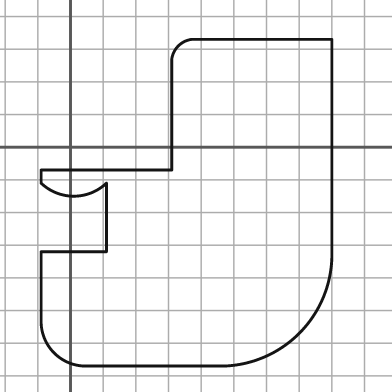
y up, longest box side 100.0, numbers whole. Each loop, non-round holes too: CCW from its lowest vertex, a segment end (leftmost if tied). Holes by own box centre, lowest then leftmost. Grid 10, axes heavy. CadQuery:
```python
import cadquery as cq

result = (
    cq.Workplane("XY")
    .moveTo(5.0, -67.0)
    .lineTo(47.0, -67.0)
    .threePointArc((70.0, -57.0), (80.0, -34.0))
    .lineTo(80.0, 33.0)
    .lineTo(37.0, 33.0)
    .threePointArc((33.0, 31.0), (31.0, 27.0))
    .lineTo(31.0, -7.0)
    .lineTo(-9.0, -7.0)
    .lineTo(-9.0, -11.0)
    .threePointArc((1.0, -15.0), (11.0, -11.0))
    .lineTo(11.0, -32.0)
    .lineTo(-9.0, -32.0)
    .lineTo(-9.0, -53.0)
    .threePointArc((-5.0, -63.0), (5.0, -67.0))
    .close()
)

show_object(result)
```